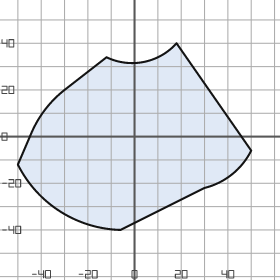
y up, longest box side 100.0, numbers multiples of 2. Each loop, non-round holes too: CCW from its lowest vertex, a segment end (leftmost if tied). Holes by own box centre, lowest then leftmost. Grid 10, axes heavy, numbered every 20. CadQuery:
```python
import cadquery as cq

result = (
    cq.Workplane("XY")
    .moveTo(-6.0, -40.0)
    .lineTo(30.0, -22.0)
    .threePointArc((42.0, -16.0), (50.0, -6.0))
    .lineTo(18.0, 40.0)
    .threePointArc((4.0, 32.0), (-12.0, 34.0))
    .lineTo(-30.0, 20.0)
    .threePointArc((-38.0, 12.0), (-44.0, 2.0))
    .lineTo(-50.0, -12.0)
    .threePointArc((-32.0, -32.0), (-6.0, -40.0))
    .close()
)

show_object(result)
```